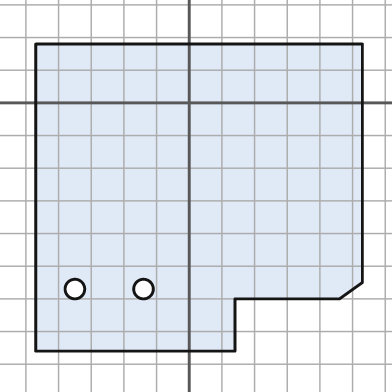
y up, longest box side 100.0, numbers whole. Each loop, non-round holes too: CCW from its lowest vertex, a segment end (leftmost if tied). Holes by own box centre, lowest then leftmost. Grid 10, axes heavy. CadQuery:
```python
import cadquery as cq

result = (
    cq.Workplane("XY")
    .moveTo(-47.0, -76.0)
    .lineTo(14.0, -76.0)
    .lineTo(14.0, -60.0)
    .lineTo(46.0, -60.0)
    .lineTo(53.0, -55.0)
    .lineTo(53.0, 18.0)
    .lineTo(-47.0, 18.0)
    .close()
    .moveTo(-35.0, -57.0)
    .circle(3.0)
    .moveTo(-14.0, -57.0)
    .circle(3.0)
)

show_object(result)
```